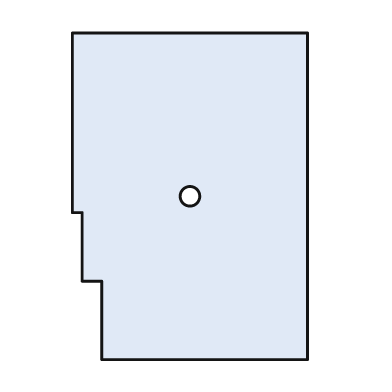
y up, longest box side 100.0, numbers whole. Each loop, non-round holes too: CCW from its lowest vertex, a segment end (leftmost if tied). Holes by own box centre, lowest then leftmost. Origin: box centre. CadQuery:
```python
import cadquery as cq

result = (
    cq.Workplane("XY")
    .moveTo(-27.0, -50.0)
    .lineTo(36.0, -50.0)
    .lineTo(36.0, 50.0)
    .lineTo(-36.0, 50.0)
    .lineTo(-36.0, -5.0)
    .lineTo(-33.0, -5.0)
    .lineTo(-33.0, -26.0)
    .lineTo(-27.0, -26.0)
    .close()
    .moveTo(0.0, 0.0)
    .circle(3.0)
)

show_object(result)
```